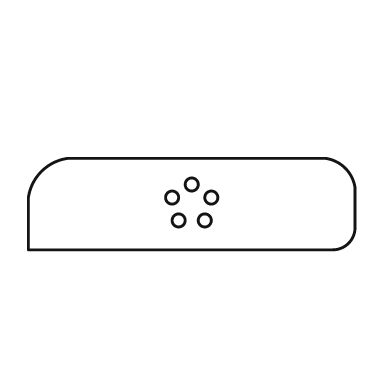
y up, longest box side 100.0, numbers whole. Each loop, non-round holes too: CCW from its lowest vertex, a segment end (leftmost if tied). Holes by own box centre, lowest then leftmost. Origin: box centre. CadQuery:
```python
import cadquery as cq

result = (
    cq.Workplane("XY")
    .moveTo(-50.0, -14.0)
    .lineTo(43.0, -14.0)
    .threePointArc((48.0, -12.0), (50.0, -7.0))
    .lineTo(50.0, 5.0)
    .threePointArc((47.0, 11.0), (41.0, 14.0))
    .lineTo(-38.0, 14.0)
    .threePointArc((-46.0, 10.0), (-50.0, 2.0))
    .close()
    .moveTo(-4.0, -5.0)
    .circle(2.0)
    .moveTo(4.0, -5.0)
    .circle(2.0)
    .moveTo(-6.0, 2.0)
    .circle(2.0)
    .moveTo(6.0, 2.0)
    .circle(2.0)
    .moveTo(0.0, 6.0)
    .circle(2.0)
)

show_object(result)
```